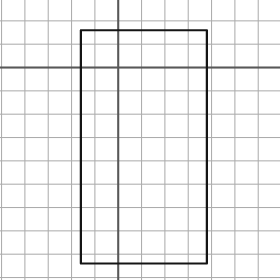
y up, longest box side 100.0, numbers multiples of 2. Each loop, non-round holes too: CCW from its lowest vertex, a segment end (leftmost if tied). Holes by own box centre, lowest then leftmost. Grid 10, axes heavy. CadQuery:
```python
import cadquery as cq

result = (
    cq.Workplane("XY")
    .moveTo(-16.0, -84.0)
    .lineTo(38.0, -84.0)
    .lineTo(38.0, 16.0)
    .lineTo(-16.0, 16.0)
    .close()
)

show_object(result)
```